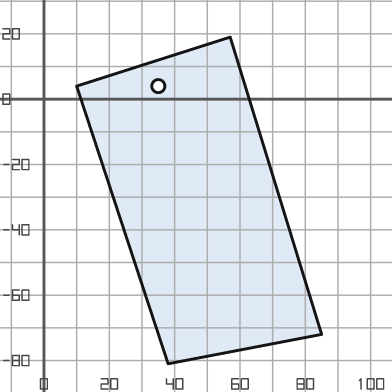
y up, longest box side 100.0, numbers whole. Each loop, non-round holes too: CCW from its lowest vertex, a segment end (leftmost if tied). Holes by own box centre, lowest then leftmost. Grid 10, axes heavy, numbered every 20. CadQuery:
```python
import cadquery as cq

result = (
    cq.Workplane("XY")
    .moveTo(38.0, -81.0)
    .lineTo(85.0, -72.0)
    .lineTo(57.0, 19.0)
    .lineTo(10.0, 4.0)
    .close()
    .moveTo(35.0, 4.0)
    .circle(2.0)
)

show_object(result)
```